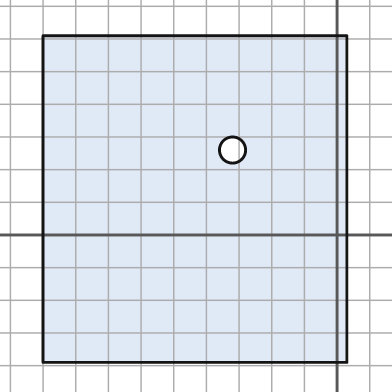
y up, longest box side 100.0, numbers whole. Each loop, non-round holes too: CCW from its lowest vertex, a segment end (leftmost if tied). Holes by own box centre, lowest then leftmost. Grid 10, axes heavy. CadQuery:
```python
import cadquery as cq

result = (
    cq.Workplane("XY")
    .moveTo(-90.0, -39.0)
    .lineTo(3.0, -39.0)
    .lineTo(3.0, 61.0)
    .lineTo(-90.0, 61.0)
    .close()
    .moveTo(-32.0, 26.0)
    .circle(4.0)
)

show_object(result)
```